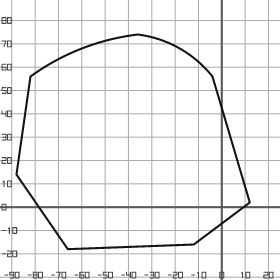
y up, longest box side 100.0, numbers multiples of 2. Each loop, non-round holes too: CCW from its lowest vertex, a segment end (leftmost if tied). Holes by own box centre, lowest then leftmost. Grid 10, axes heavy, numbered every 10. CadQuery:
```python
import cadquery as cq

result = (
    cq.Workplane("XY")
    .moveTo(-66.0, -18.0)
    .lineTo(-12.0, -16.0)
    .lineTo(12.0, 2.0)
    .lineTo(-4.0, 56.0)
    .threePointArc((-18.0, 68.0), (-36.0, 74.0))
    .threePointArc((-60.0, 68.0), (-82.0, 56.0))
    .lineTo(-88.0, 14.0)
    .close()
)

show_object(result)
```